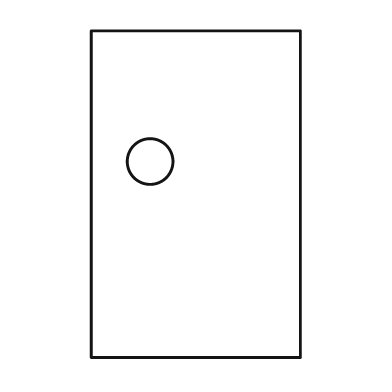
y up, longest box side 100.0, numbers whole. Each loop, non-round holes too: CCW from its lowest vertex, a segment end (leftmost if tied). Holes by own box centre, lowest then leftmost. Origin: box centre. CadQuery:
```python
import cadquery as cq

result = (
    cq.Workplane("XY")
    .moveTo(-32.0, -50.0)
    .lineTo(32.0, -50.0)
    .lineTo(32.0, 50.0)
    .lineTo(-32.0, 50.0)
    .close()
    .moveTo(-14.0, 10.0)
    .circle(7.0)
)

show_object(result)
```